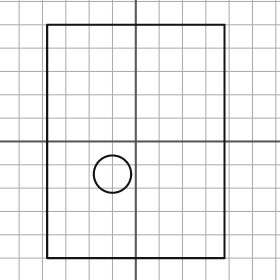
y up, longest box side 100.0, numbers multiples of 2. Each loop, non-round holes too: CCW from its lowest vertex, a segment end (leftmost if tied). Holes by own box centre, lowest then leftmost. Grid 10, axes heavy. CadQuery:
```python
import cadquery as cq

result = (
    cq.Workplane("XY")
    .moveTo(-38.0, -50.0)
    .lineTo(38.0, -50.0)
    .lineTo(38.0, 50.0)
    .lineTo(-38.0, 50.0)
    .close()
    .moveTo(-10.0, -14.0)
    .circle(8.0)
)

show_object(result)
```